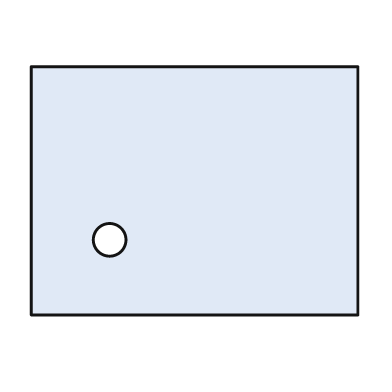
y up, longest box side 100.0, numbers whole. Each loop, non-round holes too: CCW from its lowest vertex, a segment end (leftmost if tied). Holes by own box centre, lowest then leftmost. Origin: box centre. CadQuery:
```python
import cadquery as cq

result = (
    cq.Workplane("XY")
    .moveTo(-50.0, -38.0)
    .lineTo(50.0, -38.0)
    .lineTo(50.0, 38.0)
    .lineTo(-50.0, 38.0)
    .close()
    .moveTo(-26.0, -15.0)
    .circle(5.0)
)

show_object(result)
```